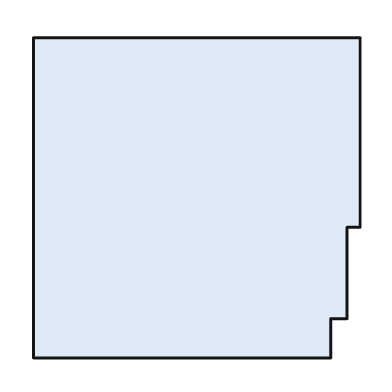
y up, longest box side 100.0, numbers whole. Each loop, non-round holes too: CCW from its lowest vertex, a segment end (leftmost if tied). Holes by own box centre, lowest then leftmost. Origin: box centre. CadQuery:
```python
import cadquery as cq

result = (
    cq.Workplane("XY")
    .moveTo(-50.0, -49.0)
    .lineTo(41.0, -49.0)
    .lineTo(41.0, -37.0)
    .lineTo(46.0, -37.0)
    .lineTo(46.0, -9.0)
    .lineTo(50.0, -9.0)
    .lineTo(50.0, 49.0)
    .lineTo(-50.0, 49.0)
    .close()
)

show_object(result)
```